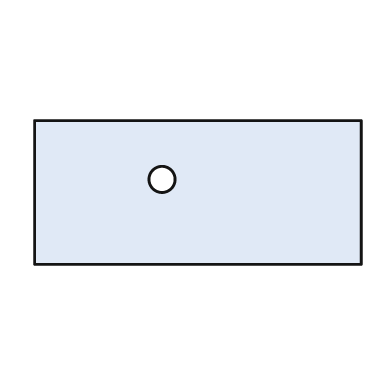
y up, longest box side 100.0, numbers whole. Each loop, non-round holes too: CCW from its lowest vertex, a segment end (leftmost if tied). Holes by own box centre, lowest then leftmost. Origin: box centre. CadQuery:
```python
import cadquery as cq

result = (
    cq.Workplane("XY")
    .moveTo(-50.0, -22.0)
    .lineTo(50.0, -22.0)
    .lineTo(50.0, 22.0)
    .lineTo(-50.0, 22.0)
    .close()
    .moveTo(-11.0, 4.0)
    .circle(4.0)
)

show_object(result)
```